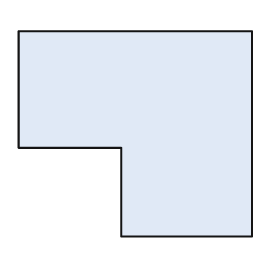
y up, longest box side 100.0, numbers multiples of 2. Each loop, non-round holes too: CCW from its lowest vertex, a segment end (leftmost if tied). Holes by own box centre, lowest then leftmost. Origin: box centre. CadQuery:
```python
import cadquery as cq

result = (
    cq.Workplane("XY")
    .moveTo(-6.0, -44.0)
    .lineTo(50.0, -44.0)
    .lineTo(50.0, 44.0)
    .lineTo(-50.0, 44.0)
    .lineTo(-50.0, -6.0)
    .lineTo(-6.0, -6.0)
    .close()
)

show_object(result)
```